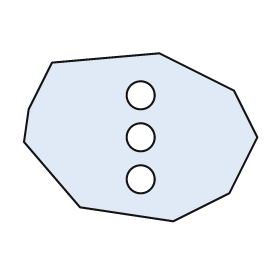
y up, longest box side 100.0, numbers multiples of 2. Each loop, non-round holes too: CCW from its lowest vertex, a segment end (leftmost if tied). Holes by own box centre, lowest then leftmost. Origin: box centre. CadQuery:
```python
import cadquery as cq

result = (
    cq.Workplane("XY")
    .moveTo(14.0, -36.0)
    .lineTo(38.0, -24.0)
    .lineTo(50.0, 0.0)
    .lineTo(40.0, 20.0)
    .lineTo(8.0, 36.0)
    .lineTo(-38.0, 32.0)
    .lineTo(-48.0, 12.0)
    .lineTo(-50.0, -2.0)
    .lineTo(-26.0, -30.0)
    .close()
    .moveTo(0.0, -18.0)
    .circle(6.0)
    .moveTo(0.0, 0.0)
    .circle(6.0)
    .moveTo(0.0, 18.0)
    .circle(6.0)
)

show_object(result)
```